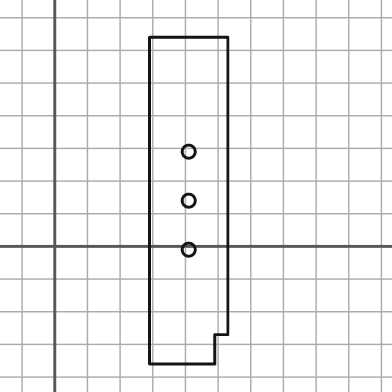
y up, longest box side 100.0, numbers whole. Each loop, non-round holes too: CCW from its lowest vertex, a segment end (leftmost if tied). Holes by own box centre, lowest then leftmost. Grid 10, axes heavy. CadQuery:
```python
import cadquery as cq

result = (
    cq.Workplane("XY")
    .moveTo(29.0, -36.0)
    .lineTo(49.0, -36.0)
    .lineTo(49.0, -27.0)
    .lineTo(53.0, -27.0)
    .lineTo(53.0, 64.0)
    .lineTo(29.0, 64.0)
    .close()
    .moveTo(41.0, -1.0)
    .circle(2.0)
    .moveTo(41.0, 14.0)
    .circle(2.0)
    .moveTo(41.0, 29.0)
    .circle(2.0)
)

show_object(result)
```